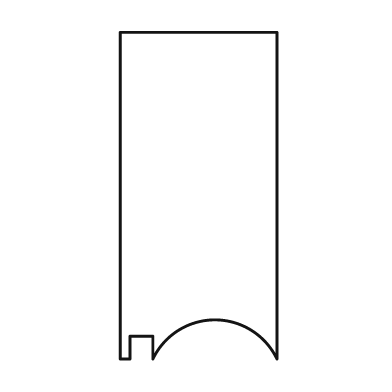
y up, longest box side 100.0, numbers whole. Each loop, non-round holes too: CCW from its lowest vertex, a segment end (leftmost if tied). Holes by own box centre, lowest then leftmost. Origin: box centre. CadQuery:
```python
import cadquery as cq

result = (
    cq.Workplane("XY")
    .moveTo(-24.0, -50.0)
    .lineTo(-21.0, -50.0)
    .lineTo(-21.0, -43.0)
    .lineTo(-14.0, -43.0)
    .lineTo(-14.0, -50.0)
    .threePointArc((5.0, -38.0), (24.0, -50.0))
    .lineTo(24.0, 50.0)
    .lineTo(-24.0, 50.0)
    .close()
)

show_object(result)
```